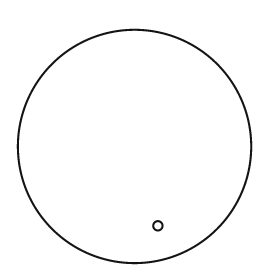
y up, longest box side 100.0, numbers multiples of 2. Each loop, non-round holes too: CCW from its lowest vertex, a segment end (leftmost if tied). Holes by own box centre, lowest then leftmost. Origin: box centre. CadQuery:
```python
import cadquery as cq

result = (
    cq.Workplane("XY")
    .moveTo(0.0, 0.0)
    .circle(50.0)
    .moveTo(10.0, -34.0)
    .circle(2.0)
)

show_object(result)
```